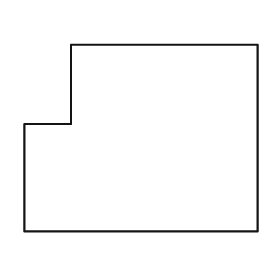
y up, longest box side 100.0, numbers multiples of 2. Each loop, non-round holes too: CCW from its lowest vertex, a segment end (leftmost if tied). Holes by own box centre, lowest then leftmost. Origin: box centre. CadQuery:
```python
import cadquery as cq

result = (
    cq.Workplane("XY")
    .moveTo(-50.0, -40.0)
    .lineTo(50.0, -40.0)
    .lineTo(50.0, 40.0)
    .lineTo(-30.0, 40.0)
    .lineTo(-30.0, 6.0)
    .lineTo(-50.0, 6.0)
    .close()
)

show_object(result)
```